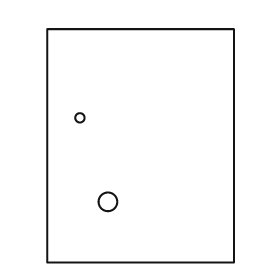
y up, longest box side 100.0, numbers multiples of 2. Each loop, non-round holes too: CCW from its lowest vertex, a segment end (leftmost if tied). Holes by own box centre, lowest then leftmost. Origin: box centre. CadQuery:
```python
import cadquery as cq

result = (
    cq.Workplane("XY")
    .moveTo(-40.0, -50.0)
    .lineTo(40.0, -50.0)
    .lineTo(40.0, 50.0)
    .lineTo(-40.0, 50.0)
    .close()
    .moveTo(-14.0, -24.0)
    .circle(4.0)
    .moveTo(-26.0, 12.0)
    .circle(2.0)
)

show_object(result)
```